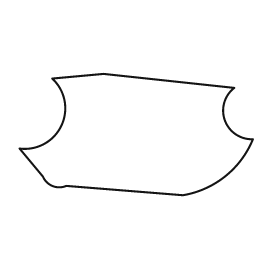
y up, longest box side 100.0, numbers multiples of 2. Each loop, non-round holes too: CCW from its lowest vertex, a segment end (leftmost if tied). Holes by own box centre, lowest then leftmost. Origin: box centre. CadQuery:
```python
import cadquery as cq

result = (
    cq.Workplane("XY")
    .moveTo(20.0, -26.0)
    .threePointArc((38.0, -18.0), (50.0, -2.0))
    .threePointArc((38.0, 6.0), (42.0, 20.0))
    .lineTo(-14.0, 26.0)
    .lineTo(-36.0, 24.0)
    .threePointArc((-32.0, 4.0), (-50.0, -6.0))
    .lineTo(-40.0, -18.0)
    .threePointArc((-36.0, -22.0), (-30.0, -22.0))
    .close()
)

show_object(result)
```